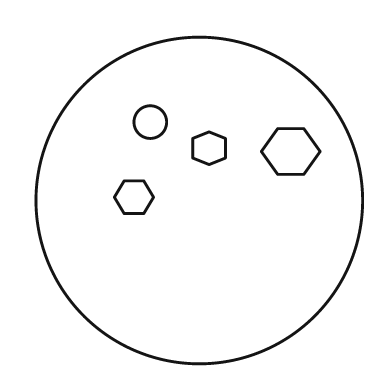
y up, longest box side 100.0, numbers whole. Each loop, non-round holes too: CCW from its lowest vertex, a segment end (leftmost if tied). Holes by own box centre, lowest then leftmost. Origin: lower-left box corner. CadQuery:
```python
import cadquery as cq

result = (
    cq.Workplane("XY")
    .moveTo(50.0, 50.0)
    .circle(50.0)
    .moveTo(27.0, 46.0)
    .lineTo(33.0, 46.0)
    .lineTo(36.0, 51.0)
    .lineTo(33.0, 56.0)
    .lineTo(27.0, 56.0)
    .lineTo(24.0, 51.0)
    .close()
    .moveTo(74.0, 58.0)
    .lineTo(82.0, 58.0)
    .lineTo(87.0, 65.0)
    .lineTo(82.0, 72.0)
    .lineTo(74.0, 72.0)
    .lineTo(69.0, 65.0)
    .close()
    .moveTo(53.0, 61.0)
    .lineTo(58.0, 63.0)
    .lineTo(58.0, 69.0)
    .lineTo(53.0, 71.0)
    .lineTo(48.0, 69.0)
    .lineTo(48.0, 63.0)
    .close()
    .moveTo(35.0, 74.0)
    .circle(5.0)
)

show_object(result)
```